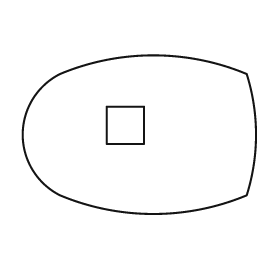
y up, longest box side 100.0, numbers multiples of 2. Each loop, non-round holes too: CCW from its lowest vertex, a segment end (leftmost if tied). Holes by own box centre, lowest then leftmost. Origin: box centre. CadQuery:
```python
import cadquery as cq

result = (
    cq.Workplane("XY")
    .moveTo(-34.0, -26.0)
    .threePointArc((6.0, -34.0), (46.0, -26.0))
    .threePointArc((50.0, 0.0), (46.0, 26.0))
    .threePointArc((6.0, 34.0), (-34.0, 26.0))
    .threePointArc((-50.0, 0.0), (-34.0, -26.0))
    .close()
    .moveTo(-14.0, -4.0)
    .lineTo(2.0, -4.0)
    .lineTo(2.0, 12.0)
    .lineTo(-14.0, 12.0)
    .close()
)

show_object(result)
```